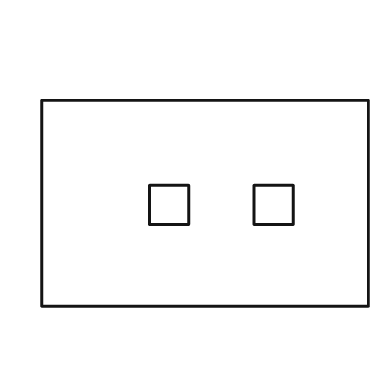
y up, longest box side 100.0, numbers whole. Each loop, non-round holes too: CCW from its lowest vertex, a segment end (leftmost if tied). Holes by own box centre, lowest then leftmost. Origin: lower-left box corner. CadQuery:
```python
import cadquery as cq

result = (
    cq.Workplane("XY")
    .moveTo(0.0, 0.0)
    .lineTo(100.0, 0.0)
    .lineTo(100.0, 63.0)
    .lineTo(0.0, 63.0)
    .close()
    .moveTo(33.0, 25.0)
    .lineTo(45.0, 25.0)
    .lineTo(45.0, 37.0)
    .lineTo(33.0, 37.0)
    .close()
    .moveTo(65.0, 25.0)
    .lineTo(77.0, 25.0)
    .lineTo(77.0, 37.0)
    .lineTo(65.0, 37.0)
    .close()
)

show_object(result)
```